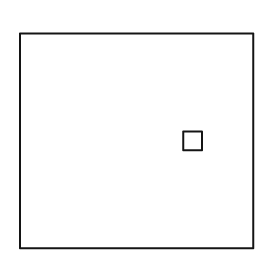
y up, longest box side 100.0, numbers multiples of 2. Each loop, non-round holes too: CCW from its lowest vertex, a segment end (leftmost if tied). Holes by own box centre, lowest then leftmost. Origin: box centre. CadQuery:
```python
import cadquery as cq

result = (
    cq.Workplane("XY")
    .moveTo(-50.0, -46.0)
    .lineTo(50.0, -46.0)
    .lineTo(50.0, 46.0)
    .lineTo(-50.0, 46.0)
    .close()
    .moveTo(20.0, -4.0)
    .lineTo(28.0, -4.0)
    .lineTo(28.0, 4.0)
    .lineTo(20.0, 4.0)
    .close()
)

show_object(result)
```